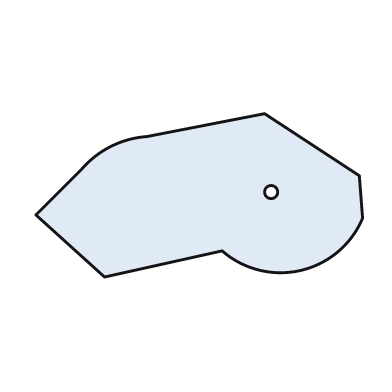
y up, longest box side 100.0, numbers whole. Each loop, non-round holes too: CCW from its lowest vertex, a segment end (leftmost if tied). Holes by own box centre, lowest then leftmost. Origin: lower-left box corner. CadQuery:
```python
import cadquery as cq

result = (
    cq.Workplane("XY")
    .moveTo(21.0, 0.0)
    .lineTo(57.0, 8.0)
    .threePointArc((81.0, 2.0), (100.0, 18.0))
    .lineTo(99.0, 31.0)
    .lineTo(70.0, 50.0)
    .lineTo(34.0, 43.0)
    .threePointArc((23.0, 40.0), (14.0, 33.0))
    .lineTo(0.0, 19.0)
    .close()
    .moveTo(72.0, 26.0)
    .circle(2.0)
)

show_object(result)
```